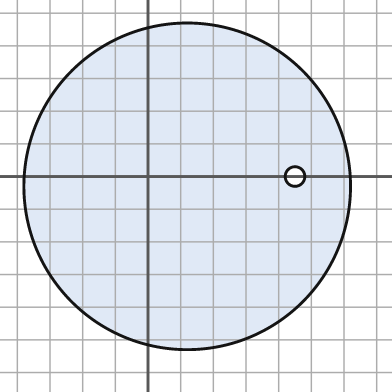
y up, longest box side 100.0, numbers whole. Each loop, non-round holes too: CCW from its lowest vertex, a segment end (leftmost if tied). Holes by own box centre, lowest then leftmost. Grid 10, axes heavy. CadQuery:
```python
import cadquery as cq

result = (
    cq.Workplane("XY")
    .moveTo(12.0, -3.0)
    .circle(50.0)
    .moveTo(45.0, 0.0)
    .circle(3.0)
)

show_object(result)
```